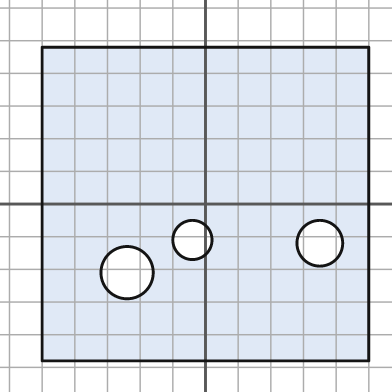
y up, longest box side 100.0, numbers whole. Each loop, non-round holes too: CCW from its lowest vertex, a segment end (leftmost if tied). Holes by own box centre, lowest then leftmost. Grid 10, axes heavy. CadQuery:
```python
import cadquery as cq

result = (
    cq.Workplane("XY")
    .moveTo(-50.0, -48.0)
    .lineTo(50.0, -48.0)
    .lineTo(50.0, 48.0)
    .lineTo(-50.0, 48.0)
    .close()
    .moveTo(-24.0, -21.0)
    .circle(8.0)
    .moveTo(35.0, -12.0)
    .circle(7.0)
    .moveTo(-4.0, -11.0)
    .circle(6.0)
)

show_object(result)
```